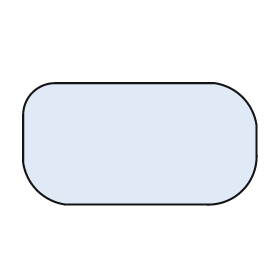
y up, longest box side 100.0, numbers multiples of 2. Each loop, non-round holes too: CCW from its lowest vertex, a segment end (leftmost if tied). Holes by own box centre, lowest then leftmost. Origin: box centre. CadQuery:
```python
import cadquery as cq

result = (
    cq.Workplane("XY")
    .moveTo(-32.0, -26.0)
    .lineTo(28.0, -26.0)
    .threePointArc((44.0, -20.0), (50.0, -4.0))
    .lineTo(50.0, 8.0)
    .threePointArc((44.0, 20.0), (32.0, 26.0))
    .lineTo(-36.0, 26.0)
    .threePointArc((-46.0, 22.0), (-50.0, 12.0))
    .lineTo(-50.0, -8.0)
    .threePointArc((-44.0, -20.0), (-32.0, -26.0))
    .close()
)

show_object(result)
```